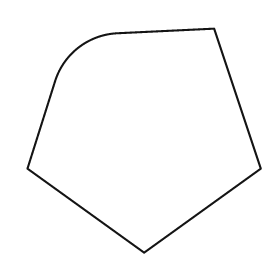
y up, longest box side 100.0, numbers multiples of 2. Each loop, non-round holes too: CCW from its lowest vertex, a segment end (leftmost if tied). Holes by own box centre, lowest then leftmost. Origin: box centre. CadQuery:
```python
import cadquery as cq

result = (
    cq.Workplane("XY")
    .moveTo(0.0, -48.0)
    .lineTo(50.0, -12.0)
    .lineTo(30.0, 48.0)
    .lineTo(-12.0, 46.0)
    .threePointArc((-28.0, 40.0), (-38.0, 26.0))
    .lineTo(-50.0, -12.0)
    .close()
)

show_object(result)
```